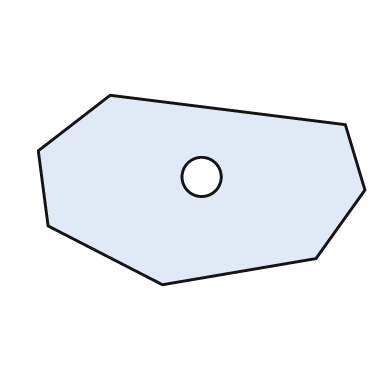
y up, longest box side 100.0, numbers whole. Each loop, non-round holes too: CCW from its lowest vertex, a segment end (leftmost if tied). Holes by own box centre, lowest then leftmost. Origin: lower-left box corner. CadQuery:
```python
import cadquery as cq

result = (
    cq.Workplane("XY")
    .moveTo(38.0, 0.0)
    .lineTo(85.0, 8.0)
    .lineTo(100.0, 29.0)
    .lineTo(94.0, 49.0)
    .lineTo(22.0, 58.0)
    .lineTo(0.0, 41.0)
    .lineTo(3.0, 18.0)
    .close()
    .moveTo(50.0, 33.0)
    .circle(6.0)
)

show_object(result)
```